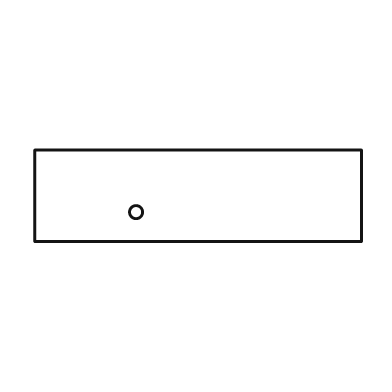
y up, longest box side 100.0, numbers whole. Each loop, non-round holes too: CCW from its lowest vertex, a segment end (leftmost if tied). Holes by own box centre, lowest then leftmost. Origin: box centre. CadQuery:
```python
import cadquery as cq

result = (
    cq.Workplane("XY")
    .moveTo(-50.0, -14.0)
    .lineTo(50.0, -14.0)
    .lineTo(50.0, 14.0)
    .lineTo(-50.0, 14.0)
    .close()
    .moveTo(-19.0, -5.0)
    .circle(2.0)
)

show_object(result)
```